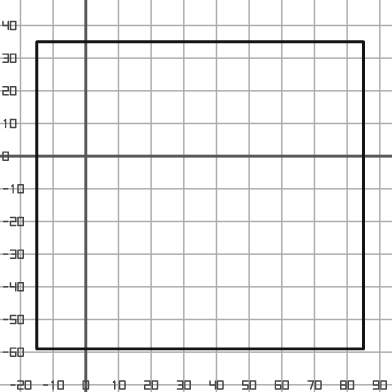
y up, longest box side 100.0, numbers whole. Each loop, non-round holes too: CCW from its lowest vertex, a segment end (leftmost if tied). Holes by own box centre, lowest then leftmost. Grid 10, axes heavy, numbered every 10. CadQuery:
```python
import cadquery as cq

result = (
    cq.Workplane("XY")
    .moveTo(-15.0, -59.0)
    .lineTo(85.0, -59.0)
    .lineTo(85.0, 35.0)
    .lineTo(-15.0, 35.0)
    .close()
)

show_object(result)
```